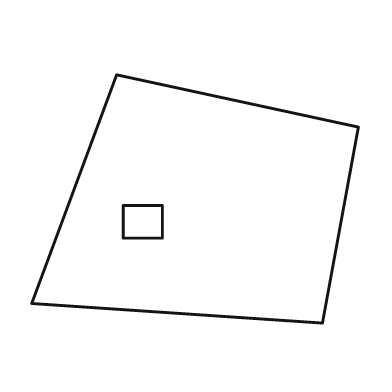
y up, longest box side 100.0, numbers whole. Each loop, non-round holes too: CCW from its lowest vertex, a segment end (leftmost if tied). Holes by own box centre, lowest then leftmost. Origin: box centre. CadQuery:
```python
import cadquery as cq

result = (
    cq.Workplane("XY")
    .moveTo(39.0, -38.0)
    .lineTo(50.0, 22.0)
    .lineTo(-24.0, 38.0)
    .lineTo(-50.0, -32.0)
    .close()
    .moveTo(-22.0, -12.0)
    .lineTo(-10.0, -12.0)
    .lineTo(-10.0, -2.0)
    .lineTo(-22.0, -2.0)
    .close()
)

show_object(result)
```